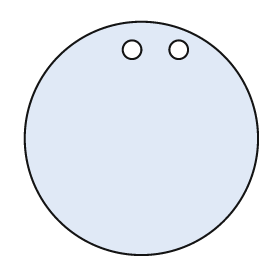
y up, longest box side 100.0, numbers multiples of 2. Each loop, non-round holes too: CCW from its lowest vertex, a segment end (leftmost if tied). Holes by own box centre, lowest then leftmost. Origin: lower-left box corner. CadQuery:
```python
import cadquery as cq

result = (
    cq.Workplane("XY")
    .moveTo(50.0, 50.0)
    .circle(50.0)
    .moveTo(46.0, 88.0)
    .circle(4.0)
    .moveTo(66.0, 88.0)
    .circle(4.0)
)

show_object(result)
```